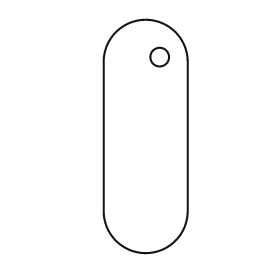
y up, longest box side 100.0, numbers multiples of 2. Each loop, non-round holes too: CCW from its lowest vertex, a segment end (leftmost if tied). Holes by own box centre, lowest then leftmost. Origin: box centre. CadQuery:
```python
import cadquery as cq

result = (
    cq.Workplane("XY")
    .moveTo(-18.0, -32.0)
    .threePointArc((0.0, -50.0), (18.0, -32.0))
    .lineTo(18.0, 32.0)
    .threePointArc((0.0, 50.0), (-18.0, 32.0))
    .close()
    .moveTo(6.0, 34.0)
    .circle(4.0)
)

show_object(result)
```